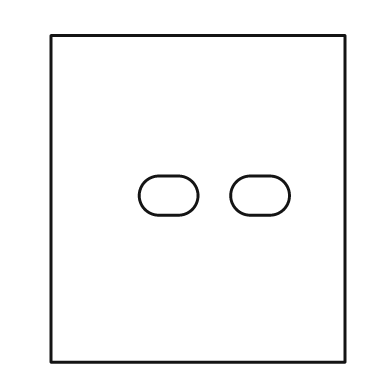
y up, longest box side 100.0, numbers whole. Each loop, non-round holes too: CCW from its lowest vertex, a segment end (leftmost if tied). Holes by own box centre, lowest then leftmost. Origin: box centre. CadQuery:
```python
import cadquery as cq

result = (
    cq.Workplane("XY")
    .moveTo(-45.0, -50.0)
    .lineTo(45.0, -50.0)
    .lineTo(45.0, 50.0)
    .lineTo(-45.0, 50.0)
    .close()
    .moveTo(-12.0, -5.0)
    .lineTo(-6.0, -5.0)
    .threePointArc((0.0, 1.0), (-6.0, 7.0))
    .lineTo(-12.0, 7.0)
    .threePointArc((-18.0, 1.0), (-12.0, -5.0))
    .close()
    .moveTo(16.0, -5.0)
    .lineTo(22.0, -5.0)
    .threePointArc((28.0, 1.0), (22.0, 7.0))
    .lineTo(16.0, 7.0)
    .threePointArc((10.0, 1.0), (16.0, -5.0))
    .close()
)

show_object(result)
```